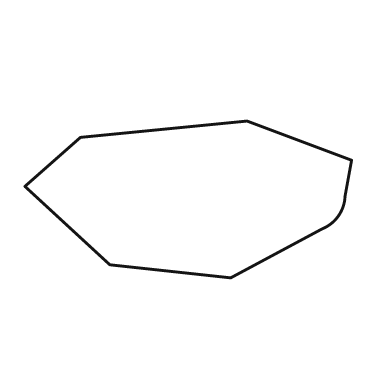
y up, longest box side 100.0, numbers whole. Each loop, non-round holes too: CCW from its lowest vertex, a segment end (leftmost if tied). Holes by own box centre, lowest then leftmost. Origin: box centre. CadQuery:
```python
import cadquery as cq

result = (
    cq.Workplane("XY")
    .moveTo(13.0, -24.0)
    .lineTo(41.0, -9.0)
    .threePointArc((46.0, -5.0), (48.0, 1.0))
    .lineTo(50.0, 12.0)
    .lineTo(18.0, 24.0)
    .lineTo(-33.0, 19.0)
    .lineTo(-50.0, 4.0)
    .lineTo(-24.0, -20.0)
    .close()
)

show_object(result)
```